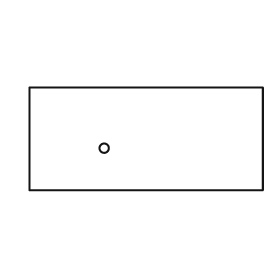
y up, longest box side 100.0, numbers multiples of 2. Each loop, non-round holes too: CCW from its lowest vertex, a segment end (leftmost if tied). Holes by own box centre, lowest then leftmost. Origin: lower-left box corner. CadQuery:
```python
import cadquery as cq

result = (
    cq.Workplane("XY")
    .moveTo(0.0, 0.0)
    .lineTo(100.0, 0.0)
    .lineTo(100.0, 44.0)
    .lineTo(0.0, 44.0)
    .close()
    .moveTo(32.0, 18.0)
    .circle(2.0)
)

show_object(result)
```